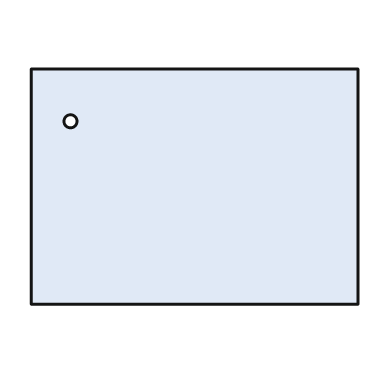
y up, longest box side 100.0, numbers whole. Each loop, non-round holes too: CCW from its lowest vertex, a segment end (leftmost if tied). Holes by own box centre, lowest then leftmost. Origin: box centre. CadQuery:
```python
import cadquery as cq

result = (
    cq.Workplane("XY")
    .moveTo(-50.0, -36.0)
    .lineTo(50.0, -36.0)
    .lineTo(50.0, 36.0)
    .lineTo(-50.0, 36.0)
    .close()
    .moveTo(-38.0, 20.0)
    .circle(2.0)
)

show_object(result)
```